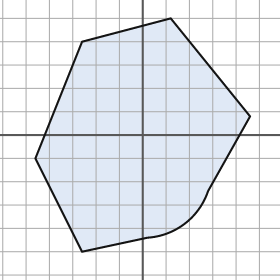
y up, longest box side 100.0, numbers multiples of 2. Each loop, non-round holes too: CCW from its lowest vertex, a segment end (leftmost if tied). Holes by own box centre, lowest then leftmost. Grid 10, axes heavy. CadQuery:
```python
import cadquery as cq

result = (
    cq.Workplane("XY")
    .moveTo(-26.0, -50.0)
    .lineTo(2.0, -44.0)
    .threePointArc((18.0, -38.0), (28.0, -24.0))
    .lineTo(46.0, 8.0)
    .lineTo(12.0, 50.0)
    .lineTo(-26.0, 40.0)
    .lineTo(-46.0, -10.0)
    .close()
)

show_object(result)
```